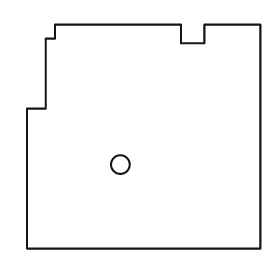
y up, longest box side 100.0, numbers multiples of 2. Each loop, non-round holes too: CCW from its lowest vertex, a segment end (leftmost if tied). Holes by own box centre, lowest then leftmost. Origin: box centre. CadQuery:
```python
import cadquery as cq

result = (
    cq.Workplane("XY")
    .moveTo(-50.0, -48.0)
    .lineTo(50.0, -48.0)
    .lineTo(50.0, 48.0)
    .lineTo(26.0, 48.0)
    .lineTo(26.0, 40.0)
    .lineTo(16.0, 40.0)
    .lineTo(16.0, 48.0)
    .lineTo(-38.0, 48.0)
    .lineTo(-38.0, 42.0)
    .lineTo(-42.0, 42.0)
    .lineTo(-42.0, 12.0)
    .lineTo(-50.0, 12.0)
    .close()
    .moveTo(-10.0, -12.0)
    .circle(4.0)
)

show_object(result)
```